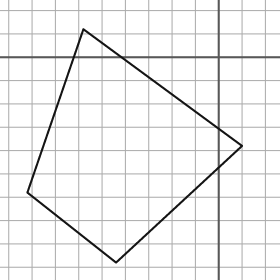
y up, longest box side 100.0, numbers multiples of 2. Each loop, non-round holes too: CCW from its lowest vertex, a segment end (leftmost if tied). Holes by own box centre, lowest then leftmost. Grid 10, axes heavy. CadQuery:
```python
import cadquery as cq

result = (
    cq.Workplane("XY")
    .moveTo(-44.0, -88.0)
    .lineTo(10.0, -38.0)
    .lineTo(-58.0, 12.0)
    .lineTo(-82.0, -58.0)
    .close()
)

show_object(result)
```